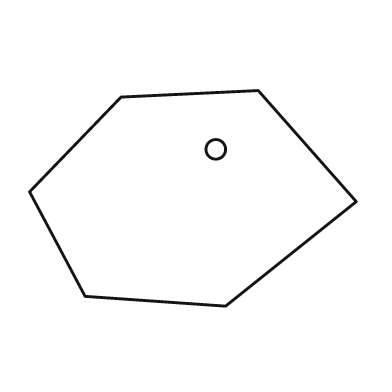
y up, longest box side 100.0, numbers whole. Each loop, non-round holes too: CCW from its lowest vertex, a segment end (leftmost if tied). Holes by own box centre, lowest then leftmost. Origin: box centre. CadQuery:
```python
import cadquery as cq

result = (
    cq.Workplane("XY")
    .moveTo(10.0, -33.0)
    .lineTo(50.0, -1.0)
    .lineTo(20.0, 33.0)
    .lineTo(-22.0, 31.0)
    .lineTo(-50.0, 2.0)
    .lineTo(-33.0, -30.0)
    .close()
    .moveTo(7.0, 15.0)
    .circle(3.0)
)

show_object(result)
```